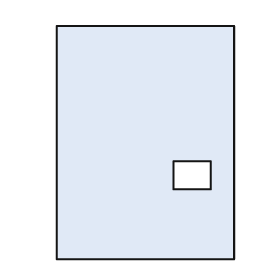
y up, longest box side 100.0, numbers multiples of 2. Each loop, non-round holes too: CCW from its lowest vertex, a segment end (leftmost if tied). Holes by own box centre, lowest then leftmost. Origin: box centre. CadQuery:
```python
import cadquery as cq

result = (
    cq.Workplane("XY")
    .moveTo(-38.0, -50.0)
    .lineTo(38.0, -50.0)
    .lineTo(38.0, 50.0)
    .lineTo(-38.0, 50.0)
    .close()
    .moveTo(12.0, -20.0)
    .lineTo(28.0, -20.0)
    .lineTo(28.0, -8.0)
    .lineTo(12.0, -8.0)
    .close()
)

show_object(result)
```